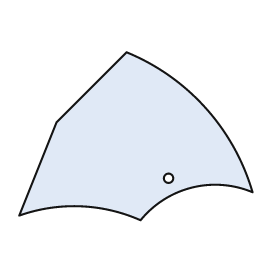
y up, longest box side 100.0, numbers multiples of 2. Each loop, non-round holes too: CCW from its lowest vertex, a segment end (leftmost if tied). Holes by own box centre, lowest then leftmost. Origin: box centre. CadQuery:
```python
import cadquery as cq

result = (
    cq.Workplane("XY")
    .moveTo(2.0, -36.0)
    .threePointArc((24.0, -22.0), (50.0, -24.0))
    .threePointArc((30.0, 12.0), (-4.0, 36.0))
    .lineTo(-34.0, 6.0)
    .lineTo(-50.0, -34.0)
    .threePointArc((-24.0, -30.0), (2.0, -36.0))
    .close()
    .moveTo(14.0, -18.0)
    .circle(2.0)
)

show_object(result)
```